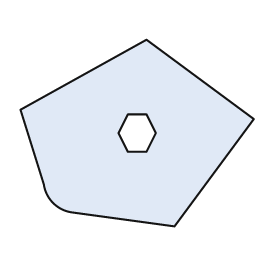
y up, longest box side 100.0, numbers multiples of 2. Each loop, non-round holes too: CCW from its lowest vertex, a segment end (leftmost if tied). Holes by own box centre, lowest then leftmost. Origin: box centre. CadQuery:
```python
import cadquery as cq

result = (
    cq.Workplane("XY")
    .moveTo(16.0, -40.0)
    .lineTo(50.0, 6.0)
    .lineTo(4.0, 40.0)
    .lineTo(-50.0, 10.0)
    .lineTo(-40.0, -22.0)
    .threePointArc((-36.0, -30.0), (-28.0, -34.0))
    .close()
    .moveTo(-4.0, -8.0)
    .lineTo(4.0, -8.0)
    .lineTo(8.0, 0.0)
    .lineTo(4.0, 8.0)
    .lineTo(-4.0, 8.0)
    .lineTo(-8.0, 0.0)
    .close()
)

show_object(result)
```